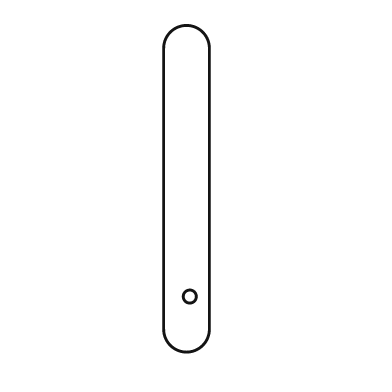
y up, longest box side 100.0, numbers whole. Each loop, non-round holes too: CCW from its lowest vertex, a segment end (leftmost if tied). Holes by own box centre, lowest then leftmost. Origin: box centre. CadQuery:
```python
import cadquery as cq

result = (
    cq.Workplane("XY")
    .moveTo(-7.0, -43.0)
    .threePointArc((0.0, -50.0), (7.0, -43.0))
    .lineTo(7.0, 43.0)
    .threePointArc((0.0, 50.0), (-7.0, 43.0))
    .close()
    .moveTo(1.0, -33.0)
    .circle(2.0)
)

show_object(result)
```